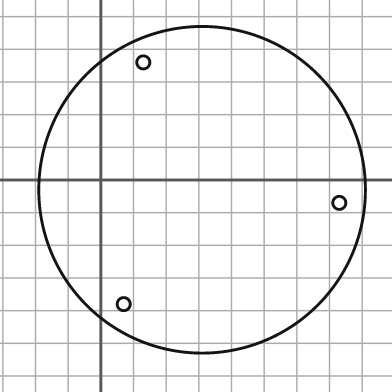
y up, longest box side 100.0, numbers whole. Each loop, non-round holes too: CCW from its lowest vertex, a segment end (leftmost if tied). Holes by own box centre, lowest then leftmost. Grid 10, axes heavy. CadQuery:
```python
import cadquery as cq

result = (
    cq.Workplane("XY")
    .moveTo(31.0, -3.0)
    .circle(50.0)
    .moveTo(7.0, -38.0)
    .circle(2.0)
    .moveTo(73.0, -7.0)
    .circle(2.0)
    .moveTo(13.0, 36.0)
    .circle(2.0)
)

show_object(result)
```